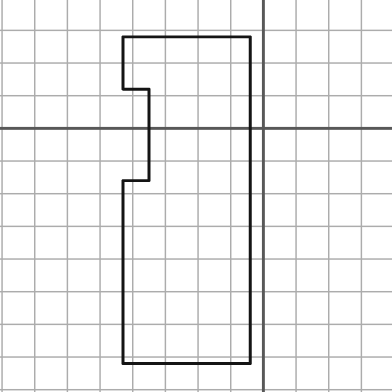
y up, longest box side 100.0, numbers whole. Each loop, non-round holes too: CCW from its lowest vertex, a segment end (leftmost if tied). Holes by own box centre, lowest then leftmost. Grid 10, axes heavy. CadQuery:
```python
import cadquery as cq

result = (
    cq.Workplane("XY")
    .moveTo(-43.0, -72.0)
    .lineTo(-4.0, -72.0)
    .lineTo(-4.0, 28.0)
    .lineTo(-43.0, 28.0)
    .lineTo(-43.0, 12.0)
    .lineTo(-35.0, 12.0)
    .lineTo(-35.0, -16.0)
    .lineTo(-43.0, -16.0)
    .close()
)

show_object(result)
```